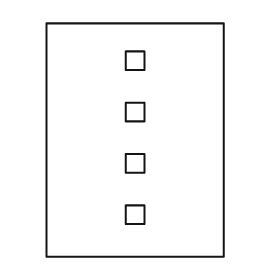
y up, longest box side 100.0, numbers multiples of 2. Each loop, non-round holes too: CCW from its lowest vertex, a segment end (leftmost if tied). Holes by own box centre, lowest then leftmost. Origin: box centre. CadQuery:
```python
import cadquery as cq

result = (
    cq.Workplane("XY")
    .moveTo(-38.0, -50.0)
    .lineTo(38.0, -50.0)
    .lineTo(38.0, 50.0)
    .lineTo(-38.0, 50.0)
    .close()
    .moveTo(-4.0, -36.0)
    .lineTo(4.0, -36.0)
    .lineTo(4.0, -28.0)
    .lineTo(-4.0, -28.0)
    .close()
    .moveTo(-4.0, -14.0)
    .lineTo(4.0, -14.0)
    .lineTo(4.0, -6.0)
    .lineTo(-4.0, -6.0)
    .close()
    .moveTo(-4.0, 8.0)
    .lineTo(4.0, 8.0)
    .lineTo(4.0, 16.0)
    .lineTo(-4.0, 16.0)
    .close()
    .moveTo(-4.0, 30.0)
    .lineTo(4.0, 30.0)
    .lineTo(4.0, 38.0)
    .lineTo(-4.0, 38.0)
    .close()
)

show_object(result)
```